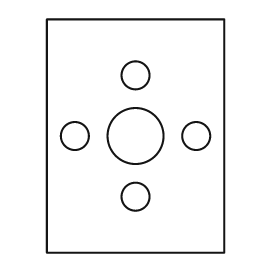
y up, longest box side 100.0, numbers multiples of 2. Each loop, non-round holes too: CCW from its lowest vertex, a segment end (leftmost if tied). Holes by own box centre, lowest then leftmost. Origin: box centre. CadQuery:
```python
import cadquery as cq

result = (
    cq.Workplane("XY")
    .moveTo(-38.0, -50.0)
    .lineTo(38.0, -50.0)
    .lineTo(38.0, 50.0)
    .lineTo(-38.0, 50.0)
    .close()
    .moveTo(0.0, -26.0)
    .circle(6.0)
    .moveTo(-26.0, 0.0)
    .circle(6.0)
    .moveTo(0.0, 0.0)
    .circle(12.0)
    .moveTo(26.0, 0.0)
    .circle(6.0)
    .moveTo(0.0, 26.0)
    .circle(6.0)
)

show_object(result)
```